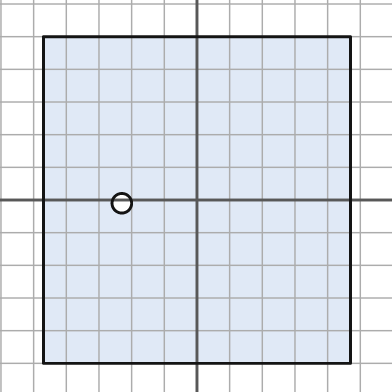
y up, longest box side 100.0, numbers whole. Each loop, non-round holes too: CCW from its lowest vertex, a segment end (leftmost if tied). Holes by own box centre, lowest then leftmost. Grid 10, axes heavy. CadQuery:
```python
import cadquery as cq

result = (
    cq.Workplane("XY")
    .moveTo(-47.0, -50.0)
    .lineTo(47.0, -50.0)
    .lineTo(47.0, 50.0)
    .lineTo(-47.0, 50.0)
    .close()
    .moveTo(-23.0, -1.0)
    .circle(3.0)
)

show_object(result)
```